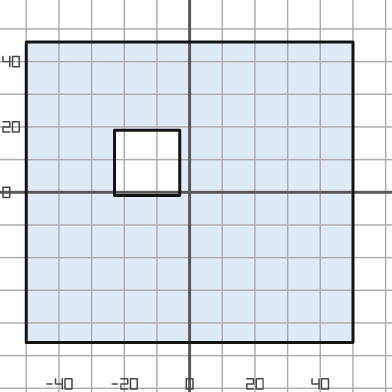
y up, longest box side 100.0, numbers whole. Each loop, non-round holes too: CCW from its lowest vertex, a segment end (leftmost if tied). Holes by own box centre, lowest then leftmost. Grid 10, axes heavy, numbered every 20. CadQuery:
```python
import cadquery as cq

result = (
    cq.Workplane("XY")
    .moveTo(-50.0, -46.0)
    .lineTo(50.0, -46.0)
    .lineTo(50.0, 46.0)
    .lineTo(-50.0, 46.0)
    .close()
    .moveTo(-23.0, -1.0)
    .lineTo(-3.0, -1.0)
    .lineTo(-3.0, 19.0)
    .lineTo(-23.0, 19.0)
    .close()
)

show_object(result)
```